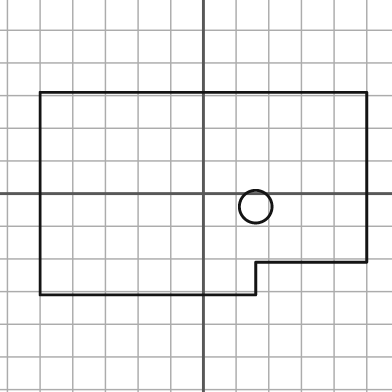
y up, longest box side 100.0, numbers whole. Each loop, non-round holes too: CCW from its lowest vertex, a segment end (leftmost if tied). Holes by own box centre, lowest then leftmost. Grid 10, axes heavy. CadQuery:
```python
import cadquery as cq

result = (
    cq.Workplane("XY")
    .moveTo(-50.0, -31.0)
    .lineTo(16.0, -31.0)
    .lineTo(16.0, -21.0)
    .lineTo(50.0, -21.0)
    .lineTo(50.0, 31.0)
    .lineTo(-50.0, 31.0)
    .close()
    .moveTo(16.0, -4.0)
    .circle(5.0)
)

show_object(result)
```